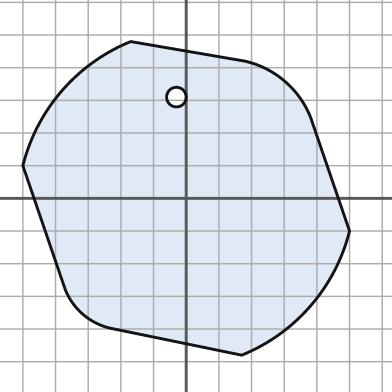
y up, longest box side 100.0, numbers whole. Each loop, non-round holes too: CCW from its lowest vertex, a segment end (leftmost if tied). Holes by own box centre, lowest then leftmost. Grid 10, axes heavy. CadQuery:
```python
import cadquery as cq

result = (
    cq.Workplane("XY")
    .moveTo(17.0, -48.0)
    .threePointArc((38.0, -33.0), (50.0, -10.0))
    .lineTo(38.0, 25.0)
    .threePointArc((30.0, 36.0), (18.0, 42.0))
    .lineTo(-17.0, 48.0)
    .threePointArc((-38.0, 33.0), (-50.0, 10.0))
    .lineTo(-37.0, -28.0)
    .threePointArc((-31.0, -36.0), (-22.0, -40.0))
    .close()
    .moveTo(-3.0, 31.0)
    .circle(3.0)
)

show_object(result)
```